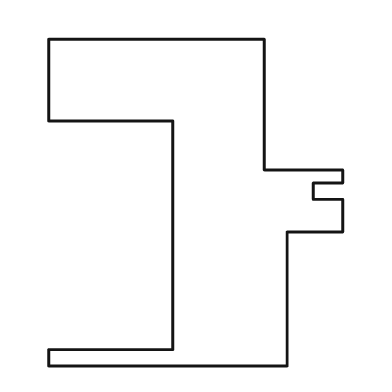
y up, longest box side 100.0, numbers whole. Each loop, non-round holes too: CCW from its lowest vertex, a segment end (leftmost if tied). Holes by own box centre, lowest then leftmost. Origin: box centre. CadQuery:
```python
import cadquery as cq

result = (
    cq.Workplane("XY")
    .moveTo(-45.0, -50.0)
    .lineTo(28.0, -50.0)
    .lineTo(28.0, -9.0)
    .lineTo(45.0, -9.0)
    .lineTo(45.0, 1.0)
    .lineTo(36.0, 1.0)
    .lineTo(36.0, 6.0)
    .lineTo(45.0, 6.0)
    .lineTo(45.0, 10.0)
    .lineTo(21.0, 10.0)
    .lineTo(21.0, 50.0)
    .lineTo(-45.0, 50.0)
    .lineTo(-45.0, 25.0)
    .lineTo(-7.0, 25.0)
    .lineTo(-7.0, -45.0)
    .lineTo(-45.0, -45.0)
    .close()
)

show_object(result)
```